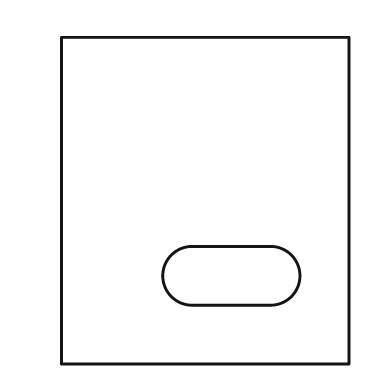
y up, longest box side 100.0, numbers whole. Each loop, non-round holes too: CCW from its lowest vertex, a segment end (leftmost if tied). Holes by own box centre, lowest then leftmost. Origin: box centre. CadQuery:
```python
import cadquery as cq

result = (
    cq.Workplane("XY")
    .moveTo(-44.0, -50.0)
    .lineTo(44.0, -50.0)
    .lineTo(44.0, 50.0)
    .lineTo(-44.0, 50.0)
    .close()
    .moveTo(-4.0, -32.0)
    .lineTo(20.0, -32.0)
    .threePointArc((29.0, -23.0), (20.0, -14.0))
    .lineTo(-4.0, -14.0)
    .threePointArc((-13.0, -23.0), (-4.0, -32.0))
    .close()
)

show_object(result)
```